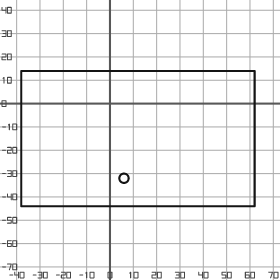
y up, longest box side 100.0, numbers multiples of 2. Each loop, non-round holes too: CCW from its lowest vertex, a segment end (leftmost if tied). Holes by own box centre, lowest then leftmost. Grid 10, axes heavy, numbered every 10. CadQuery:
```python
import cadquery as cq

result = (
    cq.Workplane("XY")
    .moveTo(-38.0, -44.0)
    .lineTo(62.0, -44.0)
    .lineTo(62.0, 14.0)
    .lineTo(-38.0, 14.0)
    .close()
    .moveTo(6.0, -32.0)
    .circle(2.0)
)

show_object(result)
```